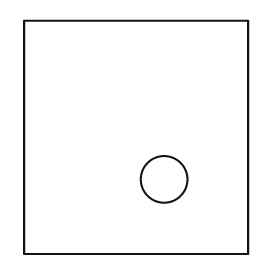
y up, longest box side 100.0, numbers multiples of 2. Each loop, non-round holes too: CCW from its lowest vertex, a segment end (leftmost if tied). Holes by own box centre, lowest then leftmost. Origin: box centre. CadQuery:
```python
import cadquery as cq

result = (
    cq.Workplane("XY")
    .moveTo(-48.0, -50.0)
    .lineTo(48.0, -50.0)
    .lineTo(48.0, 50.0)
    .lineTo(-48.0, 50.0)
    .close()
    .moveTo(12.0, -18.0)
    .circle(10.0)
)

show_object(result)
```